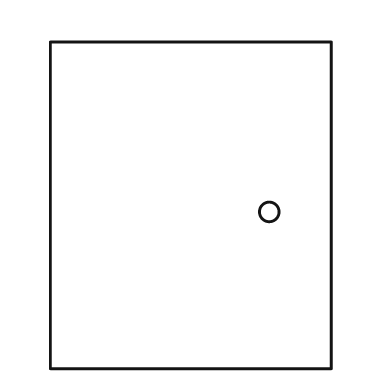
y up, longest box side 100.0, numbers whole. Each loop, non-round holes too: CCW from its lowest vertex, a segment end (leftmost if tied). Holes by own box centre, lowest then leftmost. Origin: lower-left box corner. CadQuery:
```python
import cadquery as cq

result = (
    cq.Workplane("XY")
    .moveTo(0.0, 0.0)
    .lineTo(86.0, 0.0)
    .lineTo(86.0, 100.0)
    .lineTo(0.0, 100.0)
    .close()
    .moveTo(67.0, 48.0)
    .circle(3.0)
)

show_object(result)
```